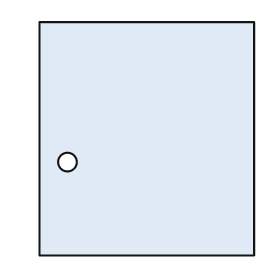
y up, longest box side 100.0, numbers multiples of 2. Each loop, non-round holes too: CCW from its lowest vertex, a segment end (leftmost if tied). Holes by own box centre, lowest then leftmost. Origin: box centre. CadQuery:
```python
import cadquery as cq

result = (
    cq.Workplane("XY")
    .moveTo(-46.0, -50.0)
    .lineTo(46.0, -50.0)
    .lineTo(46.0, 50.0)
    .lineTo(-46.0, 50.0)
    .close()
    .moveTo(-34.0, -10.0)
    .circle(4.0)
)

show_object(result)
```